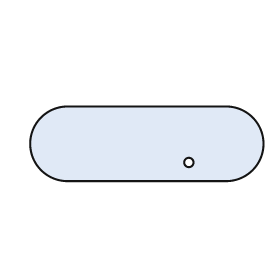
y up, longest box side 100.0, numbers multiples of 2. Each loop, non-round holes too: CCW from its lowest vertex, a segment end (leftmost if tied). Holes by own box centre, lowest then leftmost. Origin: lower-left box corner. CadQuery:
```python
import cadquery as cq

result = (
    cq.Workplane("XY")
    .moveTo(16.0, 0.0)
    .lineTo(84.0, 0.0)
    .threePointArc((100.0, 16.0), (84.0, 32.0))
    .lineTo(16.0, 32.0)
    .threePointArc((0.0, 16.0), (16.0, 0.0))
    .close()
    .moveTo(68.0, 8.0)
    .circle(2.0)
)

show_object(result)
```